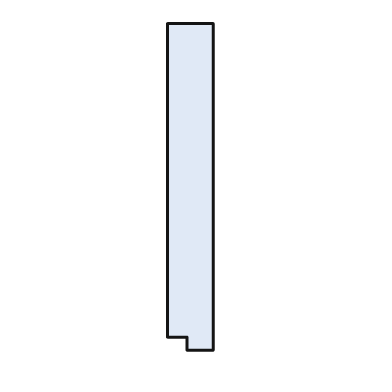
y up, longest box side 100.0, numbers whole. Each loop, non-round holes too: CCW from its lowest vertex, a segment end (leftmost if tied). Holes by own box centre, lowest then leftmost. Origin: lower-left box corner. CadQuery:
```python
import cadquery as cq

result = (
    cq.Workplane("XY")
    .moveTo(6.0, 0.0)
    .lineTo(14.0, 0.0)
    .lineTo(14.0, 100.0)
    .lineTo(0.0, 100.0)
    .lineTo(0.0, 4.0)
    .lineTo(6.0, 4.0)
    .close()
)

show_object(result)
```